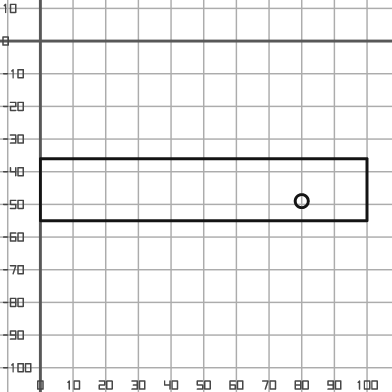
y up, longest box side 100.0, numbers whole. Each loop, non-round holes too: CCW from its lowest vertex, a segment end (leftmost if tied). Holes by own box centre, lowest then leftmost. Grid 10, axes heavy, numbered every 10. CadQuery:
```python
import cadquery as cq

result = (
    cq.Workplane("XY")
    .moveTo(0.0, -55.0)
    .lineTo(100.0, -55.0)
    .lineTo(100.0, -36.0)
    .lineTo(0.0, -36.0)
    .close()
    .moveTo(80.0, -49.0)
    .circle(2.0)
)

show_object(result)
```